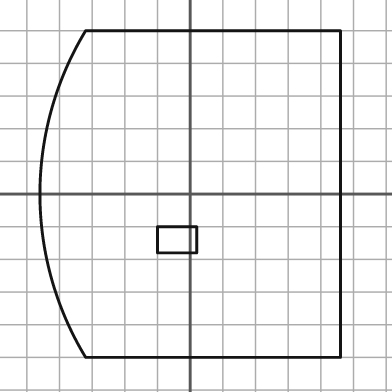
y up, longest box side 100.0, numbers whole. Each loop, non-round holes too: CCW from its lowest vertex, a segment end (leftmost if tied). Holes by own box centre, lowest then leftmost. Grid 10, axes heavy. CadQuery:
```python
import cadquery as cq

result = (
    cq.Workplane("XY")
    .moveTo(-32.0, -50.0)
    .lineTo(46.0, -50.0)
    .lineTo(46.0, 50.0)
    .lineTo(-32.0, 50.0)
    .threePointArc((-46.0, 0.0), (-32.0, -50.0))
    .close()
    .moveTo(-10.0, -18.0)
    .lineTo(2.0, -18.0)
    .lineTo(2.0, -10.0)
    .lineTo(-10.0, -10.0)
    .close()
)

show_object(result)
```